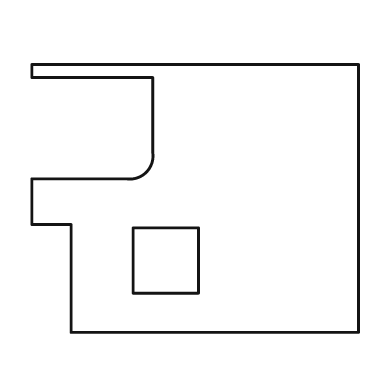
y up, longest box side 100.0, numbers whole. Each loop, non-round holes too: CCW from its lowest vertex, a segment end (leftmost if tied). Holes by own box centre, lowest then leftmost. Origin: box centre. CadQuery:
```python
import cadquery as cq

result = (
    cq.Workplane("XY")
    .moveTo(-38.0, -41.0)
    .lineTo(50.0, -41.0)
    .lineTo(50.0, 41.0)
    .lineTo(-50.0, 41.0)
    .lineTo(-50.0, 37.0)
    .lineTo(-13.0, 37.0)
    .lineTo(-13.0, 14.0)
    .threePointArc((-15.0, 8.0), (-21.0, 6.0))
    .lineTo(-50.0, 6.0)
    .lineTo(-50.0, -8.0)
    .lineTo(-38.0, -8.0)
    .close()
    .moveTo(-19.0, -29.0)
    .lineTo(1.0, -29.0)
    .lineTo(1.0, -9.0)
    .lineTo(-19.0, -9.0)
    .close()
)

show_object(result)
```